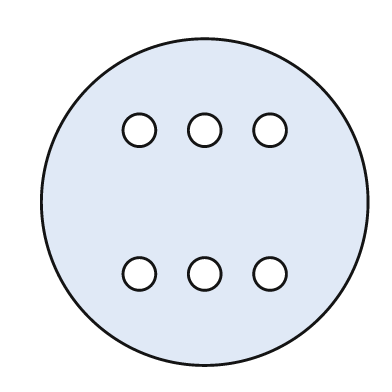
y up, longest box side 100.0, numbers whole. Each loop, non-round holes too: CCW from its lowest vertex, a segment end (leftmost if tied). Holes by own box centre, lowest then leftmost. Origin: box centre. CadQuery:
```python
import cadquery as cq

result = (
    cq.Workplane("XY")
    .moveTo(0.0, 0.0)
    .circle(50.0)
    .moveTo(-20.0, -22.0)
    .circle(5.0)
    .moveTo(0.0, -22.0)
    .circle(5.0)
    .moveTo(20.0, -22.0)
    .circle(5.0)
    .moveTo(-20.0, 22.0)
    .circle(5.0)
    .moveTo(0.0, 22.0)
    .circle(5.0)
    .moveTo(20.0, 22.0)
    .circle(5.0)
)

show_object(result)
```